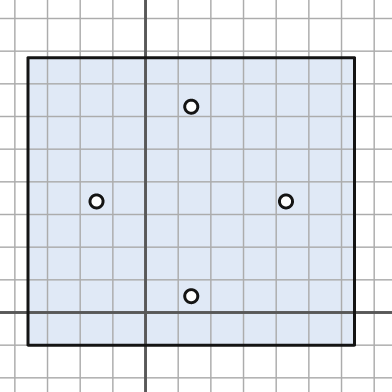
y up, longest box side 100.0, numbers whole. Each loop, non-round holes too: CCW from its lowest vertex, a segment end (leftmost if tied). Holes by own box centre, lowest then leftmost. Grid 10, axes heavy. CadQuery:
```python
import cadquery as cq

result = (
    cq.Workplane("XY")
    .moveTo(-36.0, -10.0)
    .lineTo(64.0, -10.0)
    .lineTo(64.0, 78.0)
    .lineTo(-36.0, 78.0)
    .close()
    .moveTo(14.0, 5.0)
    .circle(2.0)
    .moveTo(-15.0, 34.0)
    .circle(2.0)
    .moveTo(43.0, 34.0)
    .circle(2.0)
    .moveTo(14.0, 63.0)
    .circle(2.0)
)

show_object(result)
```